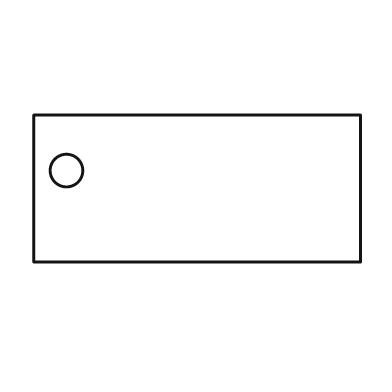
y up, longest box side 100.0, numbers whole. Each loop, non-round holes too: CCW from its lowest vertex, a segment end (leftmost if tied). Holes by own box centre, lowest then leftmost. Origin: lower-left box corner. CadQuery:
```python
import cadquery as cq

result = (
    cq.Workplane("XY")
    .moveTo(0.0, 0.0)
    .lineTo(100.0, 0.0)
    .lineTo(100.0, 45.0)
    .lineTo(0.0, 45.0)
    .close()
    .moveTo(10.0, 28.0)
    .circle(5.0)
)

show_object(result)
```